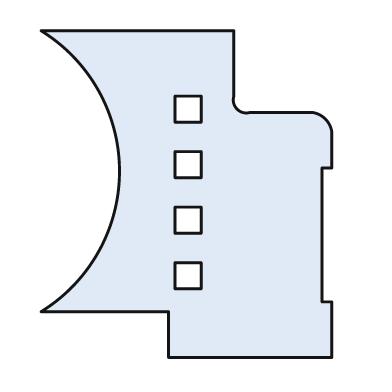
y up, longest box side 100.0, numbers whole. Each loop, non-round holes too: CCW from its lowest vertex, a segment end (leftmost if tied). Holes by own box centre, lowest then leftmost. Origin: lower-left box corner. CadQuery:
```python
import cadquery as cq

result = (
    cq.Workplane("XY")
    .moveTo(39.0, 0.0)
    .lineTo(89.0, 0.0)
    .lineTo(89.0, 17.0)
    .lineTo(86.0, 17.0)
    .lineTo(86.0, 58.0)
    .lineTo(89.0, 58.0)
    .lineTo(89.0, 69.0)
    .threePointArc((87.0, 73.0), (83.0, 75.0))
    .lineTo(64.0, 75.0)
    .threePointArc((60.0, 76.0), (59.0, 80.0))
    .lineTo(59.0, 100.0)
    .lineTo(0.0, 100.0)
    .threePointArc((24.0, 57.0), (0.0, 14.0))
    .lineTo(39.0, 14.0)
    .close()
    .moveTo(41.0, 21.0)
    .lineTo(49.0, 21.0)
    .lineTo(49.0, 29.0)
    .lineTo(41.0, 29.0)
    .close()
    .moveTo(41.0, 38.0)
    .lineTo(49.0, 38.0)
    .lineTo(49.0, 46.0)
    .lineTo(41.0, 46.0)
    .close()
    .moveTo(41.0, 55.0)
    .lineTo(49.0, 55.0)
    .lineTo(49.0, 63.0)
    .lineTo(41.0, 63.0)
    .close()
    .moveTo(41.0, 72.0)
    .lineTo(49.0, 72.0)
    .lineTo(49.0, 80.0)
    .lineTo(41.0, 80.0)
    .close()
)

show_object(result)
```